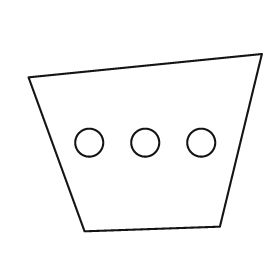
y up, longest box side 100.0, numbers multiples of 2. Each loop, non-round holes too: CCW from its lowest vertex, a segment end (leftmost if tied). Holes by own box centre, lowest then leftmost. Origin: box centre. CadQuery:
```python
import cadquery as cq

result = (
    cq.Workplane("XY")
    .moveTo(-26.0, -38.0)
    .lineTo(32.0, -36.0)
    .lineTo(50.0, 38.0)
    .lineTo(-50.0, 28.0)
    .close()
    .moveTo(-24.0, 0.0)
    .circle(6.0)
    .moveTo(0.0, 0.0)
    .circle(6.0)
    .moveTo(24.0, 0.0)
    .circle(6.0)
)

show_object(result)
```